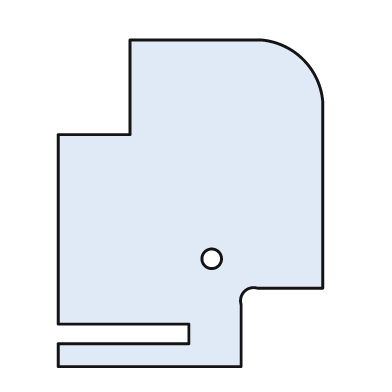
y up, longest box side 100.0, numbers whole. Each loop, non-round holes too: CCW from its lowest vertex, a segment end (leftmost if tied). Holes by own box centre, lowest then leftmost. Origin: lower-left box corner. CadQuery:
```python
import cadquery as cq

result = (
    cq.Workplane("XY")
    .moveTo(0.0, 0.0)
    .lineTo(56.0, 0.0)
    .lineTo(56.0, 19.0)
    .threePointArc((57.0, 23.0), (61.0, 24.0))
    .lineTo(81.0, 24.0)
    .lineTo(81.0, 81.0)
    .threePointArc((75.0, 94.0), (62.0, 100.0))
    .lineTo(22.0, 100.0)
    .lineTo(22.0, 71.0)
    .lineTo(0.0, 71.0)
    .lineTo(0.0, 13.0)
    .lineTo(40.0, 13.0)
    .lineTo(40.0, 7.0)
    .lineTo(0.0, 7.0)
    .close()
    .moveTo(47.0, 33.0)
    .circle(3.0)
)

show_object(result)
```